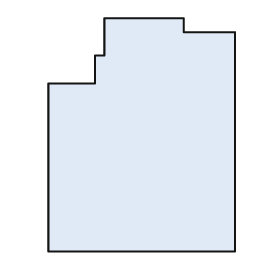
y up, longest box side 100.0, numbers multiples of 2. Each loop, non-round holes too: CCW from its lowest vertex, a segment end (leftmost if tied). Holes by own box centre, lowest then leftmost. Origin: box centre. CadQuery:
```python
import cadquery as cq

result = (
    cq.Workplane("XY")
    .moveTo(-40.0, -50.0)
    .lineTo(40.0, -50.0)
    .lineTo(40.0, 44.0)
    .lineTo(18.0, 44.0)
    .lineTo(18.0, 50.0)
    .lineTo(-16.0, 50.0)
    .lineTo(-16.0, 34.0)
    .lineTo(-20.0, 34.0)
    .lineTo(-20.0, 22.0)
    .lineTo(-40.0, 22.0)
    .close()
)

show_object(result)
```